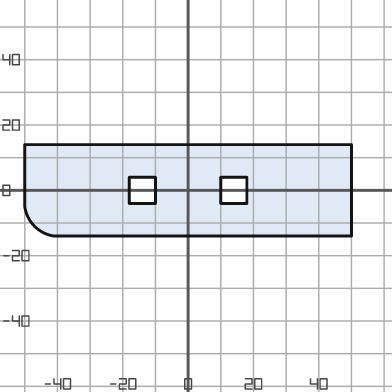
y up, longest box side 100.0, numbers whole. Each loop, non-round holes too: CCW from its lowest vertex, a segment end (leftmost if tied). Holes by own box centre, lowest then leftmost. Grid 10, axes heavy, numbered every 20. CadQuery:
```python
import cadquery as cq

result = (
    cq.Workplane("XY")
    .moveTo(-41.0, -14.0)
    .lineTo(50.0, -14.0)
    .lineTo(50.0, 14.0)
    .lineTo(-50.0, 14.0)
    .lineTo(-50.0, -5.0)
    .threePointArc((-47.0, -11.0), (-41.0, -14.0))
    .close()
    .moveTo(-18.0, -4.0)
    .lineTo(-10.0, -4.0)
    .lineTo(-10.0, 4.0)
    .lineTo(-18.0, 4.0)
    .close()
    .moveTo(10.0, -4.0)
    .lineTo(18.0, -4.0)
    .lineTo(18.0, 4.0)
    .lineTo(10.0, 4.0)
    .close()
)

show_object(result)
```